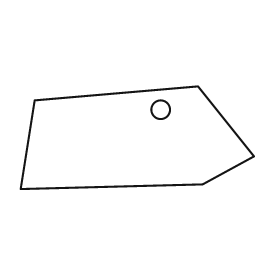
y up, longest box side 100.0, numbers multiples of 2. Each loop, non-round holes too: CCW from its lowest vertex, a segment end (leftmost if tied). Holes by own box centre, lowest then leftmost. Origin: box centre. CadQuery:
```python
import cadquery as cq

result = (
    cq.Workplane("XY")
    .moveTo(-50.0, -22.0)
    .lineTo(28.0, -20.0)
    .lineTo(50.0, -8.0)
    .lineTo(26.0, 22.0)
    .lineTo(-44.0, 16.0)
    .close()
    .moveTo(10.0, 12.0)
    .circle(4.0)
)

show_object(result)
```